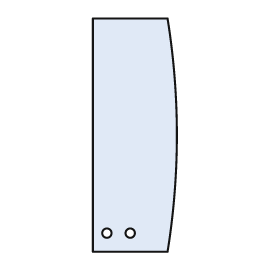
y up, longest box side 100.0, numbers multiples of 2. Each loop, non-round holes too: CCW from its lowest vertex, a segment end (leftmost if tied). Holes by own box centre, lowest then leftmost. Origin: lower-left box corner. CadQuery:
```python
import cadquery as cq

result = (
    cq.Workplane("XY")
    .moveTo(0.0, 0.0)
    .lineTo(32.0, 0.0)
    .threePointArc((36.0, 50.0), (32.0, 100.0))
    .lineTo(0.0, 100.0)
    .close()
    .moveTo(6.0, 8.0)
    .circle(2.0)
    .moveTo(16.0, 8.0)
    .circle(2.0)
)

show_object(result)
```